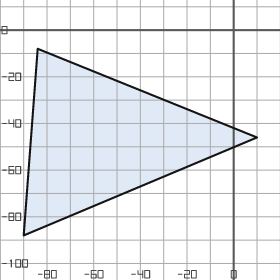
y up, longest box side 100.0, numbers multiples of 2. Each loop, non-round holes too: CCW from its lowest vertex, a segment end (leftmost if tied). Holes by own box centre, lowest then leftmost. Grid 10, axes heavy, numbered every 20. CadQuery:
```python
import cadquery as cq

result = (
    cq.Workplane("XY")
    .moveTo(-90.0, -88.0)
    .lineTo(10.0, -46.0)
    .lineTo(-84.0, -8.0)
    .close()
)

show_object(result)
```